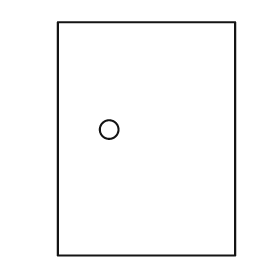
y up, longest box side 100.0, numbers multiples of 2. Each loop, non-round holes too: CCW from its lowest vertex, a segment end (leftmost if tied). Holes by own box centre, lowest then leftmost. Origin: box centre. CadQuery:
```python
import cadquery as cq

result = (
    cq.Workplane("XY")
    .moveTo(-38.0, -50.0)
    .lineTo(38.0, -50.0)
    .lineTo(38.0, 50.0)
    .lineTo(-38.0, 50.0)
    .close()
    .moveTo(-16.0, 4.0)
    .circle(4.0)
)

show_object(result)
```